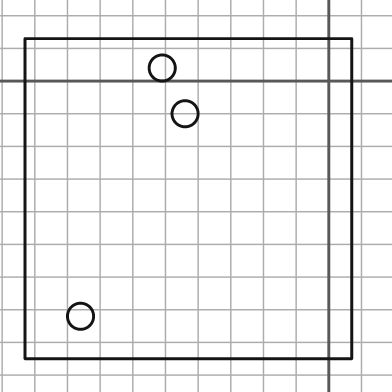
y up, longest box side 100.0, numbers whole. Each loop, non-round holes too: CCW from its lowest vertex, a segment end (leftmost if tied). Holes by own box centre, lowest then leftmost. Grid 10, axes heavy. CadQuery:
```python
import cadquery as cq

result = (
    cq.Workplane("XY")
    .moveTo(-93.0, -85.0)
    .lineTo(7.0, -85.0)
    .lineTo(7.0, 13.0)
    .lineTo(-93.0, 13.0)
    .close()
    .moveTo(-76.0, -72.0)
    .circle(4.0)
    .moveTo(-44.0, -10.0)
    .circle(4.0)
    .moveTo(-51.0, 4.0)
    .circle(4.0)
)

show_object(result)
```